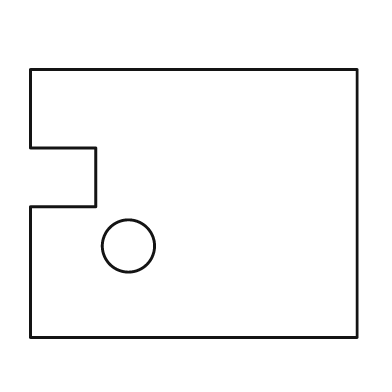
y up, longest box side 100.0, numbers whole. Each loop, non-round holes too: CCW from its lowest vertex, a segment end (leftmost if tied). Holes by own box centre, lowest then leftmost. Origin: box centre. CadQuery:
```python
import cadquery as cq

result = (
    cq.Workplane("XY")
    .moveTo(-50.0, -41.0)
    .lineTo(50.0, -41.0)
    .lineTo(50.0, 41.0)
    .lineTo(-50.0, 41.0)
    .lineTo(-50.0, 17.0)
    .lineTo(-30.0, 17.0)
    .lineTo(-30.0, -1.0)
    .lineTo(-50.0, -1.0)
    .close()
    .moveTo(-20.0, -13.0)
    .circle(8.0)
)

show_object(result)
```